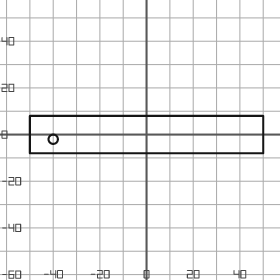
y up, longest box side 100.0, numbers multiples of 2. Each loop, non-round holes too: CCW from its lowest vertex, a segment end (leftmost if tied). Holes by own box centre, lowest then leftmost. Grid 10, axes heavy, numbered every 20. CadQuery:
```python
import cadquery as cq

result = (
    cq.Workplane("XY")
    .moveTo(-50.0, -8.0)
    .lineTo(50.0, -8.0)
    .lineTo(50.0, 8.0)
    .lineTo(-50.0, 8.0)
    .close()
    .moveTo(-40.0, -2.0)
    .circle(2.0)
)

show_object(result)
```